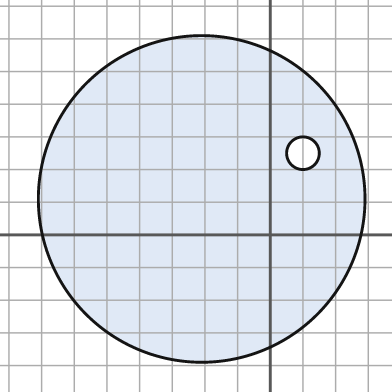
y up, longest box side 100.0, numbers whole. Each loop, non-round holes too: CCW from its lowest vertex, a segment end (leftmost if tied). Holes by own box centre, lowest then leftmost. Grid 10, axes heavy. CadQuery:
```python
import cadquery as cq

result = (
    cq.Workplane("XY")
    .moveTo(-21.0, 11.0)
    .circle(50.0)
    .moveTo(10.0, 25.0)
    .circle(5.0)
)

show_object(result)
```